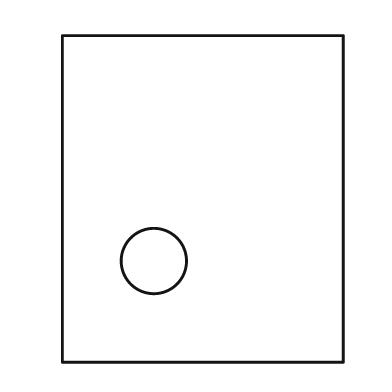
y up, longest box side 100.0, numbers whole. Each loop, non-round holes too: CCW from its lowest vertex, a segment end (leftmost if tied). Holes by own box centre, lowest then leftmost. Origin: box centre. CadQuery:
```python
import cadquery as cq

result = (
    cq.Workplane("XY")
    .moveTo(-43.0, -50.0)
    .lineTo(43.0, -50.0)
    .lineTo(43.0, 50.0)
    .lineTo(-43.0, 50.0)
    .close()
    .moveTo(-15.0, -19.0)
    .circle(10.0)
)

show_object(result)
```